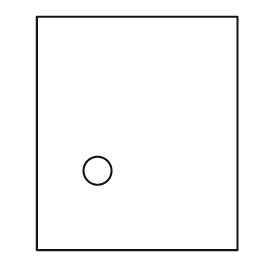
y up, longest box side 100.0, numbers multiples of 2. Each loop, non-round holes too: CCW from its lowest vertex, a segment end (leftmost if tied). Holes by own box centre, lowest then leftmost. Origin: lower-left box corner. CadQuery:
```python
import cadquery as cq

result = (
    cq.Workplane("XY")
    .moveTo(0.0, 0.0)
    .lineTo(86.0, 0.0)
    .lineTo(86.0, 100.0)
    .lineTo(0.0, 100.0)
    .close()
    .moveTo(26.0, 34.0)
    .circle(6.0)
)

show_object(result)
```